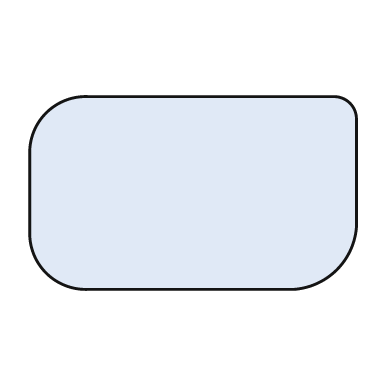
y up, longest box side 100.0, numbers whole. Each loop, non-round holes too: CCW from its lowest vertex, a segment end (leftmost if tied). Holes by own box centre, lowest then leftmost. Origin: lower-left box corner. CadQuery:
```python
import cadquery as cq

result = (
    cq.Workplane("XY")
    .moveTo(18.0, 0.0)
    .lineTo(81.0, 0.0)
    .threePointArc((94.0, 6.0), (100.0, 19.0))
    .lineTo(100.0, 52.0)
    .threePointArc((98.0, 57.0), (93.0, 59.0))
    .lineTo(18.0, 59.0)
    .threePointArc((5.0, 54.0), (0.0, 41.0))
    .lineTo(0.0, 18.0)
    .threePointArc((5.0, 5.0), (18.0, 0.0))
    .close()
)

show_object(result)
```